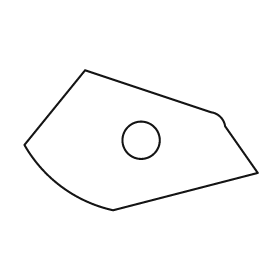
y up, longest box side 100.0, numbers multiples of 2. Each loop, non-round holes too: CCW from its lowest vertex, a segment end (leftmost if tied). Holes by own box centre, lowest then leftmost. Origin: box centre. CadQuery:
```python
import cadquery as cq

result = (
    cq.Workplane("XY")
    .moveTo(-12.0, -30.0)
    .lineTo(50.0, -14.0)
    .lineTo(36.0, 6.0)
    .threePointArc((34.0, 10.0), (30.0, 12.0))
    .lineTo(-24.0, 30.0)
    .lineTo(-50.0, -2.0)
    .threePointArc((-34.0, -20.0), (-12.0, -30.0))
    .close()
    .moveTo(0.0, 0.0)
    .circle(8.0)
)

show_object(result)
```